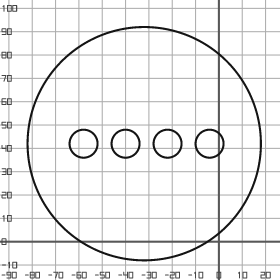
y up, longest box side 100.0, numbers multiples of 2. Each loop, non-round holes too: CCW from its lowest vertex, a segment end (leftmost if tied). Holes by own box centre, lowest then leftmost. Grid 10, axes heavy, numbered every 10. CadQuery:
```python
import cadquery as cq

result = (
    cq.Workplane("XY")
    .moveTo(-32.0, 42.0)
    .circle(50.0)
    .moveTo(-58.0, 42.0)
    .circle(6.0)
    .moveTo(-40.0, 42.0)
    .circle(6.0)
    .moveTo(-22.0, 42.0)
    .circle(6.0)
    .moveTo(-4.0, 42.0)
    .circle(6.0)
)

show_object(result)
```